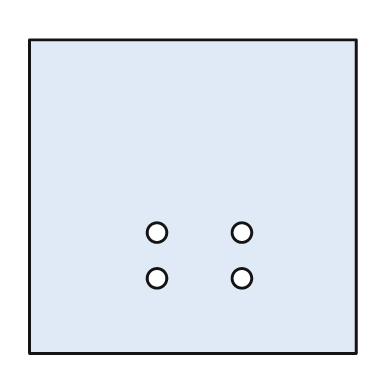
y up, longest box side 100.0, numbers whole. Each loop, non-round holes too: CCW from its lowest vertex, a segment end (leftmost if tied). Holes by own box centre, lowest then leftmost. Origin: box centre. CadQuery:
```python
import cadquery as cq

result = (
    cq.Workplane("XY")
    .moveTo(-50.0, -48.0)
    .lineTo(50.0, -48.0)
    .lineTo(50.0, 48.0)
    .lineTo(-50.0, 48.0)
    .close()
    .moveTo(-11.0, -25.0)
    .circle(3.0)
    .moveTo(15.0, -25.0)
    .circle(3.0)
    .moveTo(-11.0, -11.0)
    .circle(3.0)
    .moveTo(15.0, -11.0)
    .circle(3.0)
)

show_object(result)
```